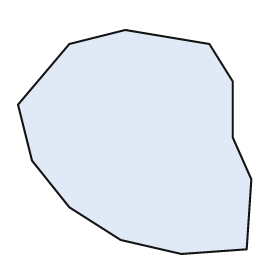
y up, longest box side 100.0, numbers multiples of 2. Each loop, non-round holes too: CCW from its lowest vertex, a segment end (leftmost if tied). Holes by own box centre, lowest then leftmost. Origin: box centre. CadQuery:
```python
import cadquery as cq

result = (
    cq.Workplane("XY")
    .moveTo(20.0, -48.0)
    .lineTo(48.0, -46.0)
    .lineTo(50.0, -16.0)
    .lineTo(42.0, 2.0)
    .lineTo(42.0, 26.0)
    .lineTo(32.0, 42.0)
    .lineTo(-4.0, 48.0)
    .lineTo(-28.0, 42.0)
    .lineTo(-50.0, 16.0)
    .lineTo(-44.0, -8.0)
    .lineTo(-28.0, -28.0)
    .lineTo(-6.0, -42.0)
    .close()
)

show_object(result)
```